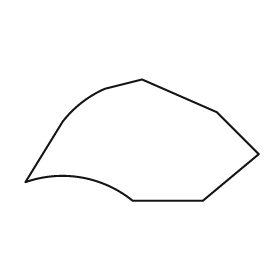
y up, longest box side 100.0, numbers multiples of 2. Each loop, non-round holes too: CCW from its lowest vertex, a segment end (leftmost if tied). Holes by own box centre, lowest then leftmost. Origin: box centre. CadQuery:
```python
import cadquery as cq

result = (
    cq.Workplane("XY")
    .moveTo(-4.0, -26.0)
    .lineTo(26.0, -26.0)
    .lineTo(50.0, -6.0)
    .lineTo(32.0, 12.0)
    .lineTo(0.0, 26.0)
    .lineTo(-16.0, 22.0)
    .threePointArc((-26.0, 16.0), (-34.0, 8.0))
    .lineTo(-50.0, -18.0)
    .threePointArc((-26.0, -16.0), (-4.0, -26.0))
    .close()
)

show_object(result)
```